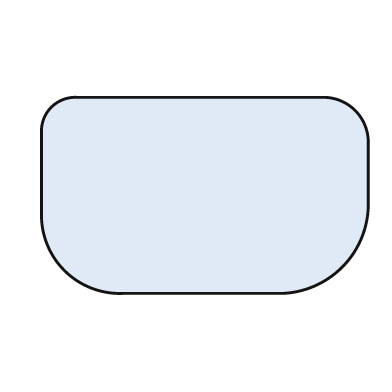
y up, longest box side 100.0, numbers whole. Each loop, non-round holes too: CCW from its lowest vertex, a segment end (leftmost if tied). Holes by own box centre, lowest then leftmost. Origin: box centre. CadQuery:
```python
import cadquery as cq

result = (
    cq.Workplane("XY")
    .moveTo(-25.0, -30.0)
    .lineTo(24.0, -30.0)
    .threePointArc((42.0, -22.0), (50.0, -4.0))
    .lineTo(50.0, 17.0)
    .threePointArc((46.0, 26.0), (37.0, 30.0))
    .lineTo(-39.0, 30.0)
    .threePointArc((-47.0, 27.0), (-50.0, 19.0))
    .lineTo(-50.0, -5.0)
    .threePointArc((-43.0, -23.0), (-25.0, -30.0))
    .close()
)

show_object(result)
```